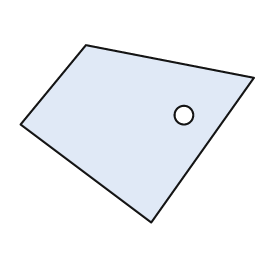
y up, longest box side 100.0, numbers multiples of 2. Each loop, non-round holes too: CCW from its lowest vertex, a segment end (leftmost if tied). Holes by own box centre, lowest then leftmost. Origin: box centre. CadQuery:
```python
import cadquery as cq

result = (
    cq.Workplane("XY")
    .moveTo(6.0, -38.0)
    .lineTo(50.0, 24.0)
    .lineTo(-22.0, 38.0)
    .lineTo(-50.0, 4.0)
    .close()
    .moveTo(20.0, 8.0)
    .circle(4.0)
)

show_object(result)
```